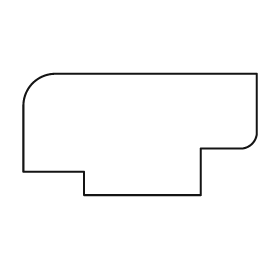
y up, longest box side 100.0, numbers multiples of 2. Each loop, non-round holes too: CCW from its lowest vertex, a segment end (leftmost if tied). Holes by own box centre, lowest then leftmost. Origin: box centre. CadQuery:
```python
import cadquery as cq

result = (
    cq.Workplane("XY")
    .moveTo(-24.0, -26.0)
    .lineTo(26.0, -26.0)
    .lineTo(26.0, -6.0)
    .lineTo(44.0, -6.0)
    .threePointArc((48.0, -4.0), (50.0, 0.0))
    .lineTo(50.0, 26.0)
    .lineTo(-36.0, 26.0)
    .threePointArc((-46.0, 22.0), (-50.0, 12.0))
    .lineTo(-50.0, -16.0)
    .lineTo(-24.0, -16.0)
    .close()
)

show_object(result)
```